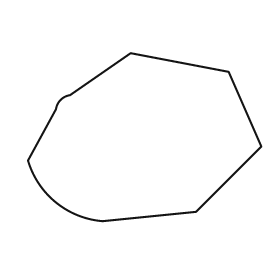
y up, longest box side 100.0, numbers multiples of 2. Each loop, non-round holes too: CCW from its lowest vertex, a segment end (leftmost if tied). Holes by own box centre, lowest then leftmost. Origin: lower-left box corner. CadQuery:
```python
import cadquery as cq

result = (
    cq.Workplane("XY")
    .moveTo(32.0, 0.0)
    .lineTo(72.0, 4.0)
    .lineTo(100.0, 32.0)
    .lineTo(86.0, 64.0)
    .lineTo(44.0, 72.0)
    .lineTo(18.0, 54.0)
    .threePointArc((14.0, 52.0), (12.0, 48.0))
    .lineTo(0.0, 26.0)
    .threePointArc((12.0, 8.0), (32.0, 0.0))
    .close()
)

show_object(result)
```